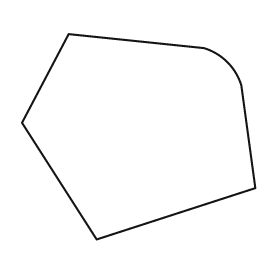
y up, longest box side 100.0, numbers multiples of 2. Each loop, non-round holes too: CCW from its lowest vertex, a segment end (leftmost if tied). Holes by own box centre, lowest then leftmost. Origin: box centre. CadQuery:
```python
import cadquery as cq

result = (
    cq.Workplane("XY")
    .moveTo(-18.0, -44.0)
    .lineTo(50.0, -22.0)
    .lineTo(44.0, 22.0)
    .threePointArc((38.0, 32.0), (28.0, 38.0))
    .lineTo(-30.0, 44.0)
    .lineTo(-50.0, 6.0)
    .close()
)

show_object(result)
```